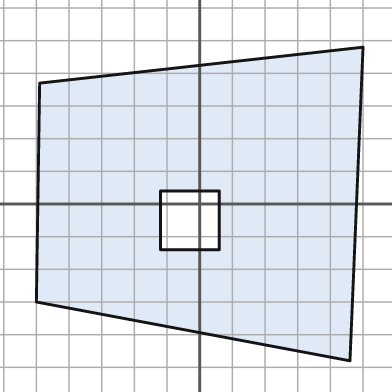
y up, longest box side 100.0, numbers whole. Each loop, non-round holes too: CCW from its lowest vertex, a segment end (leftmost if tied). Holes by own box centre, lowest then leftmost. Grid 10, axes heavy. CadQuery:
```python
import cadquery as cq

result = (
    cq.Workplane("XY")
    .moveTo(46.0, -48.0)
    .lineTo(50.0, 48.0)
    .lineTo(-49.0, 37.0)
    .lineTo(-50.0, -30.0)
    .close()
    .moveTo(-12.0, -14.0)
    .lineTo(6.0, -14.0)
    .lineTo(6.0, 4.0)
    .lineTo(-12.0, 4.0)
    .close()
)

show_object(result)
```